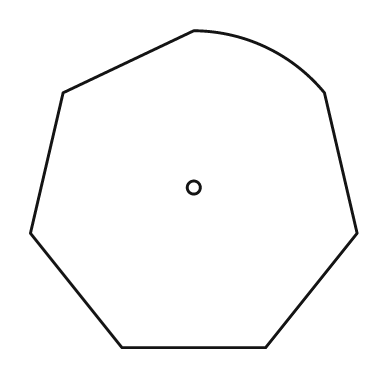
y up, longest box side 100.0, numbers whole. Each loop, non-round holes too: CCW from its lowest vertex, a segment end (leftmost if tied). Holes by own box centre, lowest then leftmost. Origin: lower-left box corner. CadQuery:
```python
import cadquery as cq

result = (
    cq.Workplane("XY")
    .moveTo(28.0, 0.0)
    .lineTo(72.0, 0.0)
    .lineTo(100.0, 35.0)
    .lineTo(90.0, 78.0)
    .threePointArc((72.0, 92.0), (50.0, 97.0))
    .lineTo(10.0, 78.0)
    .lineTo(0.0, 35.0)
    .close()
    .moveTo(50.0, 49.0)
    .circle(2.0)
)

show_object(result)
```